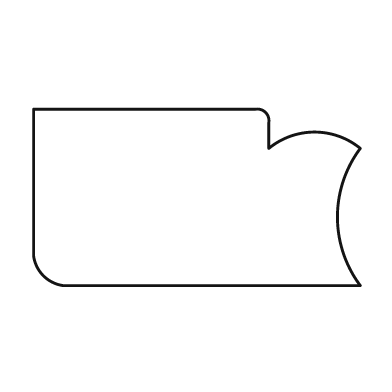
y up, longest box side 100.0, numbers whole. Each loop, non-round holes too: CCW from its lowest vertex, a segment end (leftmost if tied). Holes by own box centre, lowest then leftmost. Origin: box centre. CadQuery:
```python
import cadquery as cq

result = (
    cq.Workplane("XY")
    .moveTo(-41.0, -27.0)
    .lineTo(50.0, -27.0)
    .threePointArc((43.0, -6.0), (50.0, 15.0))
    .threePointArc((36.0, 20.0), (22.0, 15.0))
    .lineTo(22.0, 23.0)
    .threePointArc((21.0, 26.0), (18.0, 27.0))
    .lineTo(-50.0, 27.0)
    .lineTo(-50.0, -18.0)
    .threePointArc((-47.0, -24.0), (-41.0, -27.0))
    .close()
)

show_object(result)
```